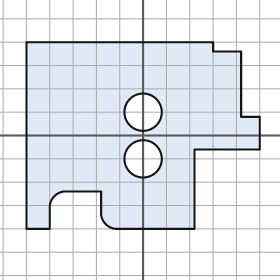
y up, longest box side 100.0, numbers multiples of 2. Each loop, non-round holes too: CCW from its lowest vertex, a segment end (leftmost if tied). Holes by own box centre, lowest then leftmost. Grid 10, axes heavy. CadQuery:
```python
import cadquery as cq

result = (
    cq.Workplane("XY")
    .moveTo(-50.0, -40.0)
    .lineTo(-40.0, -40.0)
    .lineTo(-40.0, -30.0)
    .threePointArc((-38.0, -26.0), (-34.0, -24.0))
    .lineTo(-18.0, -24.0)
    .lineTo(-18.0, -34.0)
    .threePointArc((-16.0, -38.0), (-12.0, -40.0))
    .lineTo(22.0, -40.0)
    .lineTo(22.0, -6.0)
    .lineTo(50.0, -6.0)
    .lineTo(50.0, 8.0)
    .lineTo(42.0, 8.0)
    .lineTo(42.0, 36.0)
    .lineTo(30.0, 36.0)
    .lineTo(30.0, 40.0)
    .lineTo(-50.0, 40.0)
    .close()
    .moveTo(0.0, -10.0)
    .circle(8.0)
    .moveTo(0.0, 10.0)
    .circle(8.0)
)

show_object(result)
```